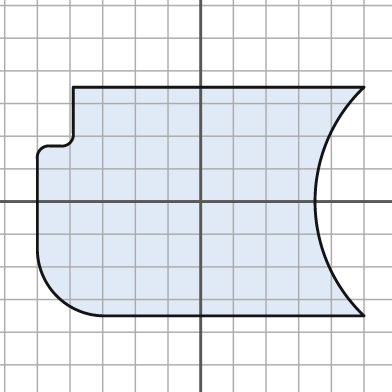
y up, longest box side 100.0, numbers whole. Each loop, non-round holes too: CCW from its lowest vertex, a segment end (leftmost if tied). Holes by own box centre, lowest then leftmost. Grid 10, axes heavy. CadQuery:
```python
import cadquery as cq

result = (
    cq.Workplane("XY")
    .moveTo(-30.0, -35.0)
    .lineTo(50.0, -35.0)
    .threePointArc((35.0, 0.0), (50.0, 35.0))
    .lineTo(-39.0, 35.0)
    .lineTo(-39.0, 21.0)
    .threePointArc((-40.0, 18.0), (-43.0, 17.0))
    .lineTo(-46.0, 17.0)
    .threePointArc((-49.0, 16.0), (-50.0, 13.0))
    .lineTo(-50.0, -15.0)
    .threePointArc((-44.0, -29.0), (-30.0, -35.0))
    .close()
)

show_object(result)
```